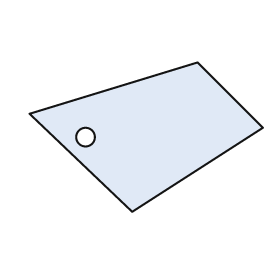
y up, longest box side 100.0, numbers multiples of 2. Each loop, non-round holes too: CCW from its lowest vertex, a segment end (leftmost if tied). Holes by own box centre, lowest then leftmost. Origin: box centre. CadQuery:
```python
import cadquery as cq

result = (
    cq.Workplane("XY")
    .moveTo(-6.0, -32.0)
    .lineTo(50.0, 4.0)
    .lineTo(22.0, 32.0)
    .lineTo(-50.0, 10.0)
    .close()
    .moveTo(-26.0, 0.0)
    .circle(4.0)
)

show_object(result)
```